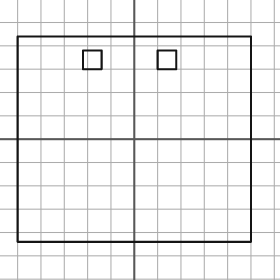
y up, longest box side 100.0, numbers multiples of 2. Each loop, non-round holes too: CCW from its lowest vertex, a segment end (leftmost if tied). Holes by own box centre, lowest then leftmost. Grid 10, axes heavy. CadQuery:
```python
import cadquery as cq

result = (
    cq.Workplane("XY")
    .moveTo(-50.0, -44.0)
    .lineTo(50.0, -44.0)
    .lineTo(50.0, 44.0)
    .lineTo(-50.0, 44.0)
    .close()
    .moveTo(-22.0, 30.0)
    .lineTo(-14.0, 30.0)
    .lineTo(-14.0, 38.0)
    .lineTo(-22.0, 38.0)
    .close()
    .moveTo(10.0, 30.0)
    .lineTo(18.0, 30.0)
    .lineTo(18.0, 38.0)
    .lineTo(10.0, 38.0)
    .close()
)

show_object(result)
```